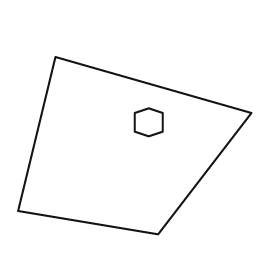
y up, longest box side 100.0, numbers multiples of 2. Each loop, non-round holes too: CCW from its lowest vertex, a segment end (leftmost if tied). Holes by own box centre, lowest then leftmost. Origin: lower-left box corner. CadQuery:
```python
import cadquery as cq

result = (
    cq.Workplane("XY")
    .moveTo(60.0, 0.0)
    .lineTo(100.0, 52.0)
    .lineTo(16.0, 76.0)
    .lineTo(0.0, 10.0)
    .close()
    .moveTo(56.0, 42.0)
    .lineTo(62.0, 44.0)
    .lineTo(62.0, 52.0)
    .lineTo(56.0, 54.0)
    .lineTo(50.0, 52.0)
    .lineTo(50.0, 44.0)
    .close()
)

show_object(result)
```